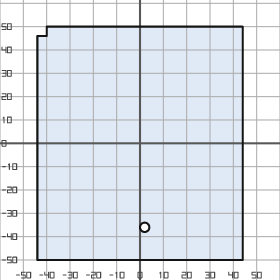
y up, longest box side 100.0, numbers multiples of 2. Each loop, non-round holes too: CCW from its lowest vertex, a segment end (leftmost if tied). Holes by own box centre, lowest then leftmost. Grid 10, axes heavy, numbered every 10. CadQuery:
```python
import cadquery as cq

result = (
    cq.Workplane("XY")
    .moveTo(-44.0, -50.0)
    .lineTo(44.0, -50.0)
    .lineTo(44.0, 50.0)
    .lineTo(-40.0, 50.0)
    .lineTo(-40.0, 46.0)
    .lineTo(-44.0, 46.0)
    .close()
    .moveTo(2.0, -36.0)
    .circle(2.0)
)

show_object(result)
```